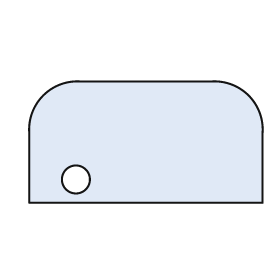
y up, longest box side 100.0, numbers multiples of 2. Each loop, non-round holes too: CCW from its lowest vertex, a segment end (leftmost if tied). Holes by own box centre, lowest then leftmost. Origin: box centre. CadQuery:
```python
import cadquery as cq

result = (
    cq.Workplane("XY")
    .moveTo(-50.0, -26.0)
    .lineTo(50.0, -26.0)
    .lineTo(50.0, 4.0)
    .threePointArc((44.0, 20.0), (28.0, 26.0))
    .lineTo(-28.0, 26.0)
    .threePointArc((-44.0, 20.0), (-50.0, 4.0))
    .close()
    .moveTo(-30.0, -16.0)
    .circle(6.0)
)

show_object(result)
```